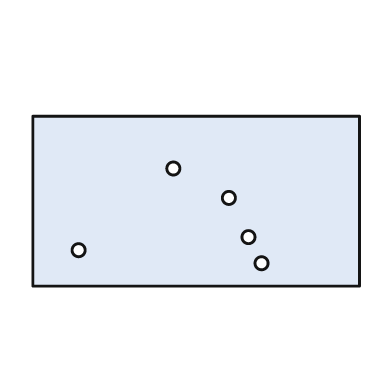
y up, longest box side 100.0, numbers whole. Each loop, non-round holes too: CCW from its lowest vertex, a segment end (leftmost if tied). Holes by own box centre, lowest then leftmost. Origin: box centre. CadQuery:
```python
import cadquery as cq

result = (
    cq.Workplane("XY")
    .moveTo(-50.0, -26.0)
    .lineTo(50.0, -26.0)
    .lineTo(50.0, 26.0)
    .lineTo(-50.0, 26.0)
    .close()
    .moveTo(20.0, -19.0)
    .circle(2.0)
    .moveTo(-36.0, -15.0)
    .circle(2.0)
    .moveTo(16.0, -11.0)
    .circle(2.0)
    .moveTo(10.0, 1.0)
    .circle(2.0)
    .moveTo(-7.0, 10.0)
    .circle(2.0)
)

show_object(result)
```